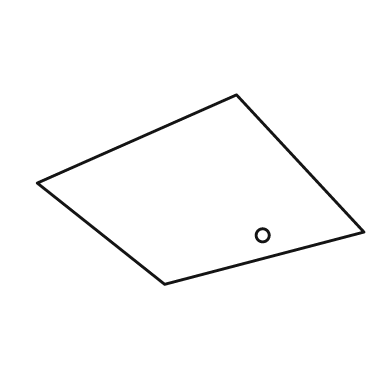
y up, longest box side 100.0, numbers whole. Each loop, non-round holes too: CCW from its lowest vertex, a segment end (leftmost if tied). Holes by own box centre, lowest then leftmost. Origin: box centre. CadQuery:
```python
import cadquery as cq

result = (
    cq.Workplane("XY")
    .moveTo(-11.0, -29.0)
    .lineTo(50.0, -13.0)
    .lineTo(11.0, 29.0)
    .lineTo(-50.0, 2.0)
    .close()
    .moveTo(19.0, -14.0)
    .circle(2.0)
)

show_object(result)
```